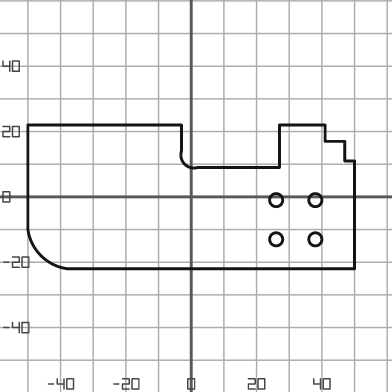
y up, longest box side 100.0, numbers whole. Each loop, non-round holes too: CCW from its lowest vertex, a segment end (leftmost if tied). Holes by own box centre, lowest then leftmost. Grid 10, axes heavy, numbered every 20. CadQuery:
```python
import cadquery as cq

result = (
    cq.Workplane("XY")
    .moveTo(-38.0, -22.0)
    .lineTo(50.0, -22.0)
    .lineTo(50.0, 11.0)
    .lineTo(47.0, 11.0)
    .lineTo(47.0, 17.0)
    .lineTo(41.0, 17.0)
    .lineTo(41.0, 22.0)
    .lineTo(27.0, 22.0)
    .lineTo(27.0, 9.0)
    .lineTo(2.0, 9.0)
    .threePointArc((-2.0, 10.0), (-3.0, 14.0))
    .lineTo(-3.0, 22.0)
    .lineTo(-50.0, 22.0)
    .lineTo(-50.0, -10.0)
    .threePointArc((-46.0, -18.0), (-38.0, -22.0))
    .close()
    .moveTo(26.0, -13.0)
    .circle(2.0)
    .moveTo(38.0, -13.0)
    .circle(2.0)
    .moveTo(26.0, -1.0)
    .circle(2.0)
    .moveTo(38.0, -1.0)
    .circle(2.0)
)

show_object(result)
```